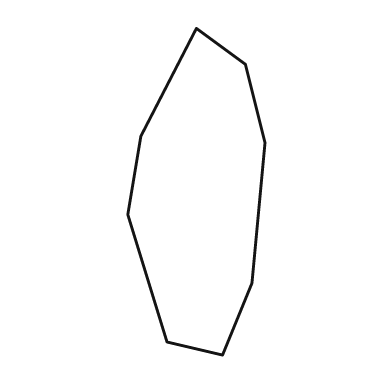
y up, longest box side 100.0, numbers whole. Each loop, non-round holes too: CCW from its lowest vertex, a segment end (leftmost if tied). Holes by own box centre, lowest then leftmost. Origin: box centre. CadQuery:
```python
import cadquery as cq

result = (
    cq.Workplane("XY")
    .moveTo(8.0, -50.0)
    .lineTo(17.0, -28.0)
    .lineTo(21.0, 15.0)
    .lineTo(15.0, 39.0)
    .lineTo(0.0, 50.0)
    .lineTo(-17.0, 17.0)
    .lineTo(-21.0, -7.0)
    .lineTo(-9.0, -46.0)
    .close()
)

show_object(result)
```